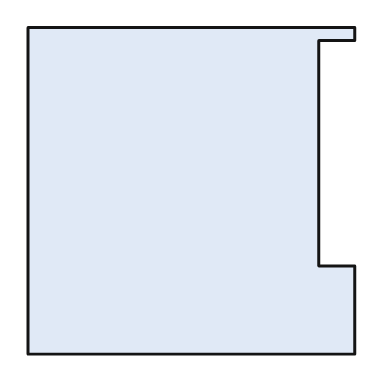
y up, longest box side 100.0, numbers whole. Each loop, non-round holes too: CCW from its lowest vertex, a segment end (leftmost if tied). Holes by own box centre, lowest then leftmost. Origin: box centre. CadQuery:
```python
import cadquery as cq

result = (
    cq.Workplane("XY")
    .moveTo(-50.0, -50.0)
    .lineTo(50.0, -50.0)
    .lineTo(50.0, -23.0)
    .lineTo(39.0, -23.0)
    .lineTo(39.0, 46.0)
    .lineTo(50.0, 46.0)
    .lineTo(50.0, 50.0)
    .lineTo(-50.0, 50.0)
    .close()
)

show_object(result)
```